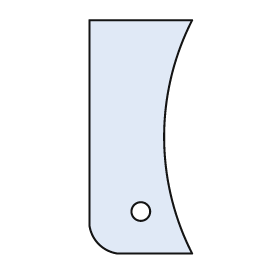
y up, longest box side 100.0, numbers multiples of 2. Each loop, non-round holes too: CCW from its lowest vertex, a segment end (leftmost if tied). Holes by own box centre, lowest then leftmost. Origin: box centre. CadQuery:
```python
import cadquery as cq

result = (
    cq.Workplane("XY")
    .moveTo(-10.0, -50.0)
    .lineTo(22.0, -50.0)
    .threePointArc((10.0, 0.0), (22.0, 50.0))
    .lineTo(-22.0, 50.0)
    .lineTo(-22.0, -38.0)
    .threePointArc((-18.0, -46.0), (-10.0, -50.0))
    .close()
    .moveTo(0.0, -32.0)
    .circle(4.0)
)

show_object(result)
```